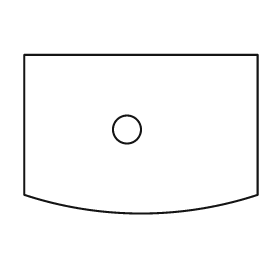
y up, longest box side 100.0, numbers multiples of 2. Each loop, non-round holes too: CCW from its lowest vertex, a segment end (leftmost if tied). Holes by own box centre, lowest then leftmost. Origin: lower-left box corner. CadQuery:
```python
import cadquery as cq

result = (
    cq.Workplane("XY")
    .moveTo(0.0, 8.0)
    .threePointArc((50.0, 0.0), (100.0, 8.0))
    .lineTo(100.0, 68.0)
    .lineTo(0.0, 68.0)
    .close()
    .moveTo(44.0, 36.0)
    .circle(6.0)
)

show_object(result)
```